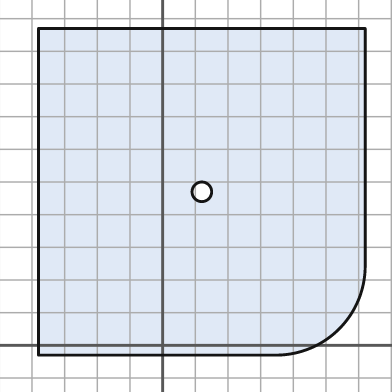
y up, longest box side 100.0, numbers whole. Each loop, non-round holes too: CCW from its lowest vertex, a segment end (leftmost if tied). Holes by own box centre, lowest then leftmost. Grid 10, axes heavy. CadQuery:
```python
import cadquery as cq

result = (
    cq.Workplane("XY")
    .moveTo(-38.0, -3.0)
    .lineTo(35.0, -3.0)
    .threePointArc((54.0, 5.0), (62.0, 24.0))
    .lineTo(62.0, 97.0)
    .lineTo(-38.0, 97.0)
    .close()
    .moveTo(12.0, 47.0)
    .circle(3.0)
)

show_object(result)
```